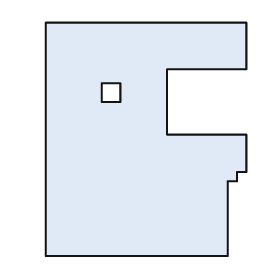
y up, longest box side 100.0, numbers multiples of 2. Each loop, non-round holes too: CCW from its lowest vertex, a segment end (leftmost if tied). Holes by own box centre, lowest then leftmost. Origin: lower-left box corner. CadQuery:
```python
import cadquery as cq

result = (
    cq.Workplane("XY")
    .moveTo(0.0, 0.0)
    .lineTo(78.0, 0.0)
    .lineTo(78.0, 32.0)
    .lineTo(82.0, 32.0)
    .lineTo(82.0, 36.0)
    .lineTo(86.0, 36.0)
    .lineTo(86.0, 52.0)
    .lineTo(52.0, 52.0)
    .lineTo(52.0, 80.0)
    .lineTo(86.0, 80.0)
    .lineTo(86.0, 100.0)
    .lineTo(0.0, 100.0)
    .close()
    .moveTo(24.0, 66.0)
    .lineTo(32.0, 66.0)
    .lineTo(32.0, 74.0)
    .lineTo(24.0, 74.0)
    .close()
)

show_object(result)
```